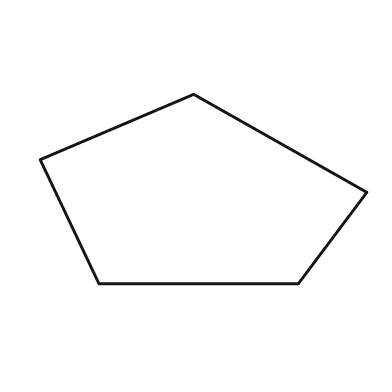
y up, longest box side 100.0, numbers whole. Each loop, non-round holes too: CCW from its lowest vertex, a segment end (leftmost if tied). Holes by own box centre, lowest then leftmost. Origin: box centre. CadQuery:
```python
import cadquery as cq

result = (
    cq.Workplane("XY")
    .moveTo(-32.0, -29.0)
    .lineTo(29.0, -29.0)
    .lineTo(50.0, -1.0)
    .lineTo(-3.0, 29.0)
    .lineTo(-50.0, 9.0)
    .close()
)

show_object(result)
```